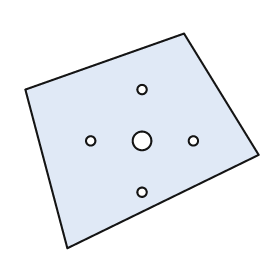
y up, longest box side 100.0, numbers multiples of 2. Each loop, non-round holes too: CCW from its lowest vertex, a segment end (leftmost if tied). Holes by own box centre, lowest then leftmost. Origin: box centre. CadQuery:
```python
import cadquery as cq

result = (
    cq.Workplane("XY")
    .moveTo(-32.0, -46.0)
    .lineTo(50.0, -6.0)
    .lineTo(18.0, 46.0)
    .lineTo(-50.0, 22.0)
    .close()
    .moveTo(0.0, -22.0)
    .circle(2.0)
    .moveTo(-22.0, 0.0)
    .circle(2.0)
    .moveTo(0.0, 0.0)
    .circle(4.0)
    .moveTo(22.0, 0.0)
    .circle(2.0)
    .moveTo(0.0, 22.0)
    .circle(2.0)
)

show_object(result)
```